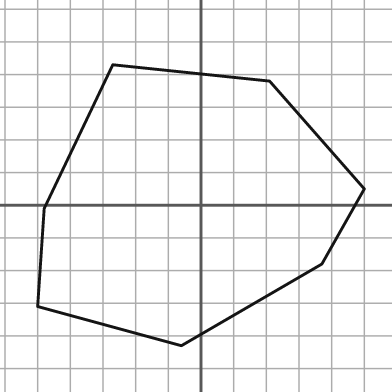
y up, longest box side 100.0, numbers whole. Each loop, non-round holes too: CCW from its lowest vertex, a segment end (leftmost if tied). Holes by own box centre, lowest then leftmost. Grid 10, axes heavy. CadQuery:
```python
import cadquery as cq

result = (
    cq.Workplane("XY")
    .moveTo(-6.0, -43.0)
    .lineTo(37.0, -18.0)
    .lineTo(50.0, 5.0)
    .lineTo(21.0, 38.0)
    .lineTo(-27.0, 43.0)
    .lineTo(-48.0, -1.0)
    .lineTo(-50.0, -31.0)
    .close()
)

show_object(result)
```